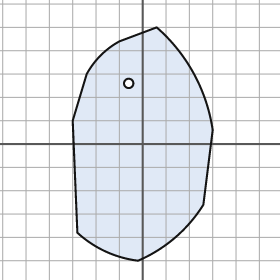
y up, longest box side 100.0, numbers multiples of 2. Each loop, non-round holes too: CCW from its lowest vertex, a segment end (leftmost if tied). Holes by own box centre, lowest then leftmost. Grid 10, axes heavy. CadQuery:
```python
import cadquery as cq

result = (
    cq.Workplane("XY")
    .moveTo(-2.0, -50.0)
    .threePointArc((14.0, -40.0), (26.0, -26.0))
    .lineTo(30.0, 6.0)
    .threePointArc((22.0, 30.0), (6.0, 50.0))
    .lineTo(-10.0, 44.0)
    .threePointArc((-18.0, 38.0), (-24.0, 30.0))
    .lineTo(-30.0, 10.0)
    .lineTo(-28.0, -38.0)
    .threePointArc((-16.0, -46.0), (-2.0, -50.0))
    .close()
    .moveTo(-6.0, 26.0)
    .circle(2.0)
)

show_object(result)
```